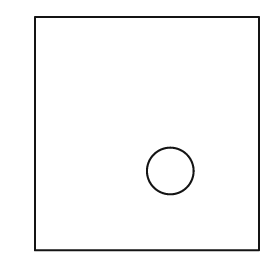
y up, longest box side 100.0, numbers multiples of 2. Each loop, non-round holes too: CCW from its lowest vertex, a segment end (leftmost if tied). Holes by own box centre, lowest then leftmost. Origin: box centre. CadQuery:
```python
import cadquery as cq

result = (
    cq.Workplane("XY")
    .moveTo(-48.0, -50.0)
    .lineTo(48.0, -50.0)
    .lineTo(48.0, 50.0)
    .lineTo(-48.0, 50.0)
    .close()
    .moveTo(10.0, -16.0)
    .circle(10.0)
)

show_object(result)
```